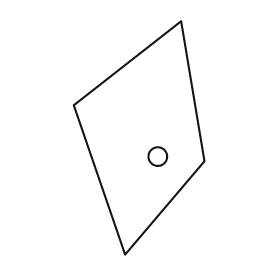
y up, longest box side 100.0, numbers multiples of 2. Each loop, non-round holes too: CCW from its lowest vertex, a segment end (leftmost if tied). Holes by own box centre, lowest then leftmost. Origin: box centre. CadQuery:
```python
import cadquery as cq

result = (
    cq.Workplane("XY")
    .moveTo(-6.0, -50.0)
    .lineTo(28.0, -10.0)
    .lineTo(18.0, 50.0)
    .lineTo(-28.0, 14.0)
    .close()
    .moveTo(8.0, -8.0)
    .circle(4.0)
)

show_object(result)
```